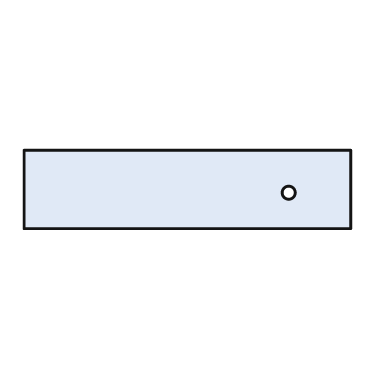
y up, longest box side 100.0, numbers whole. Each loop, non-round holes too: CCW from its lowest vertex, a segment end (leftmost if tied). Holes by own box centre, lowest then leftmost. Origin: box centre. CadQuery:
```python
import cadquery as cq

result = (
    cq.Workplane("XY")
    .moveTo(-50.0, -12.0)
    .lineTo(50.0, -12.0)
    .lineTo(50.0, 12.0)
    .lineTo(-50.0, 12.0)
    .close()
    .moveTo(31.0, -1.0)
    .circle(2.0)
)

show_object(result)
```